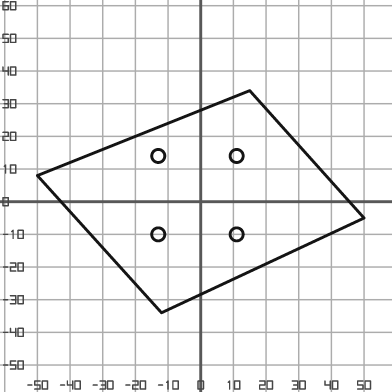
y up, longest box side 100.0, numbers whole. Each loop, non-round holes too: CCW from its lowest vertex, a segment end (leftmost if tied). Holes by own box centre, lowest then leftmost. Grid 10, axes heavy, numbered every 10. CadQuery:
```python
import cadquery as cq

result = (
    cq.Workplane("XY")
    .moveTo(-12.0, -34.0)
    .lineTo(50.0, -5.0)
    .lineTo(15.0, 34.0)
    .lineTo(-50.0, 8.0)
    .close()
    .moveTo(-13.0, -10.0)
    .circle(2.0)
    .moveTo(11.0, -10.0)
    .circle(2.0)
    .moveTo(-13.0, 14.0)
    .circle(2.0)
    .moveTo(11.0, 14.0)
    .circle(2.0)
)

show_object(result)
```